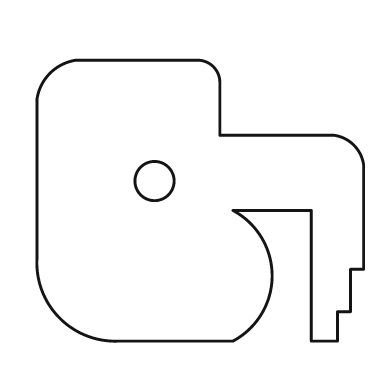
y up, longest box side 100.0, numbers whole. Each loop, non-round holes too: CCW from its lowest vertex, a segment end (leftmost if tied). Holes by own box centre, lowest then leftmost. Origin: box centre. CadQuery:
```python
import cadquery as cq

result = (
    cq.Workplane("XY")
    .moveTo(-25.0, -43.0)
    .lineTo(10.0, -43.0)
    .threePointArc((22.0, -23.0), (10.0, -3.0))
    .lineTo(34.0, -3.0)
    .lineTo(34.0, -43.0)
    .lineTo(42.0, -43.0)
    .lineTo(42.0, -34.0)
    .lineTo(46.0, -34.0)
    .lineTo(46.0, -21.0)
    .lineTo(50.0, -21.0)
    .lineTo(50.0, 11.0)
    .threePointArc((47.0, 17.0), (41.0, 20.0))
    .lineTo(6.0, 20.0)
    .lineTo(6.0, 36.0)
    .threePointArc((4.0, 41.0), (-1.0, 43.0))
    .lineTo(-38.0, 43.0)
    .threePointArc((-46.0, 39.0), (-50.0, 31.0))
    .lineTo(-50.0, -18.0)
    .threePointArc((-43.0, -36.0), (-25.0, -43.0))
    .close()
    .moveTo(-14.0, 6.0)
    .circle(6.0)
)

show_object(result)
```